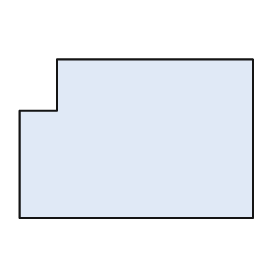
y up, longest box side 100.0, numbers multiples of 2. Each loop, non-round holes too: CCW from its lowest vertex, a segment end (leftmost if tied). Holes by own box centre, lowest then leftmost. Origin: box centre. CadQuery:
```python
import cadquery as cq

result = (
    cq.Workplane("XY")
    .moveTo(-50.0, -34.0)
    .lineTo(50.0, -34.0)
    .lineTo(50.0, 34.0)
    .lineTo(-34.0, 34.0)
    .lineTo(-34.0, 12.0)
    .lineTo(-50.0, 12.0)
    .close()
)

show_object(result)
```